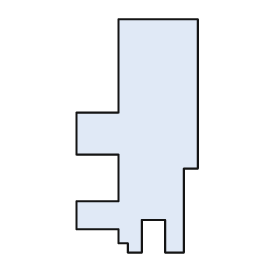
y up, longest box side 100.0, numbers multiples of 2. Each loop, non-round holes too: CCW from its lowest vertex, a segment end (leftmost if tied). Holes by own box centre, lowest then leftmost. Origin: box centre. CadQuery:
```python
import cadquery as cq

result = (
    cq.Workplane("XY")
    .moveTo(-4.0, -50.0)
    .lineTo(2.0, -50.0)
    .lineTo(2.0, -36.0)
    .lineTo(12.0, -36.0)
    .lineTo(12.0, -50.0)
    .lineTo(20.0, -50.0)
    .lineTo(20.0, -14.0)
    .lineTo(26.0, -14.0)
    .lineTo(26.0, 50.0)
    .lineTo(-8.0, 50.0)
    .lineTo(-8.0, 10.0)
    .lineTo(-26.0, 10.0)
    .lineTo(-26.0, -8.0)
    .lineTo(-8.0, -8.0)
    .lineTo(-8.0, -28.0)
    .lineTo(-26.0, -28.0)
    .lineTo(-26.0, -40.0)
    .lineTo(-8.0, -40.0)
    .lineTo(-8.0, -46.0)
    .lineTo(-4.0, -46.0)
    .close()
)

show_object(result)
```